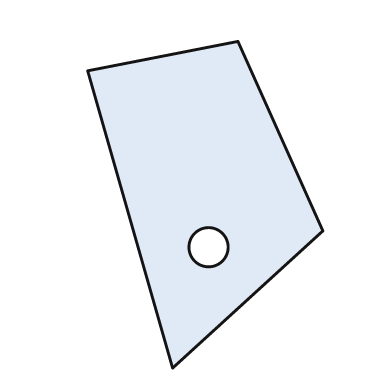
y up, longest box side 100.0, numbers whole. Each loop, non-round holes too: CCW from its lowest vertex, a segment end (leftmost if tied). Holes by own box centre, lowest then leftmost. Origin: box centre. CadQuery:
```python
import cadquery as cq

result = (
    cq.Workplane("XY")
    .moveTo(-10.0, -50.0)
    .lineTo(36.0, -8.0)
    .lineTo(10.0, 50.0)
    .lineTo(-36.0, 41.0)
    .close()
    .moveTo(1.0, -13.0)
    .circle(6.0)
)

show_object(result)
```